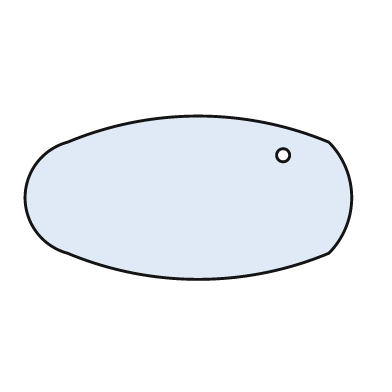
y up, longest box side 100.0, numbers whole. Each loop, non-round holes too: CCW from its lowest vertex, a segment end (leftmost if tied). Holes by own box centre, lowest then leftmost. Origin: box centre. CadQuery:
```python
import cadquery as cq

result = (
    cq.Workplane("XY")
    .moveTo(-37.0, -17.0)
    .threePointArc((3.0, -25.0), (43.0, -17.0))
    .threePointArc((50.0, 0.0), (43.0, 17.0))
    .threePointArc((3.0, 25.0), (-37.0, 17.0))
    .threePointArc((-50.0, 0.0), (-37.0, -17.0))
    .close()
    .moveTo(29.0, 13.0)
    .circle(2.0)
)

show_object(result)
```